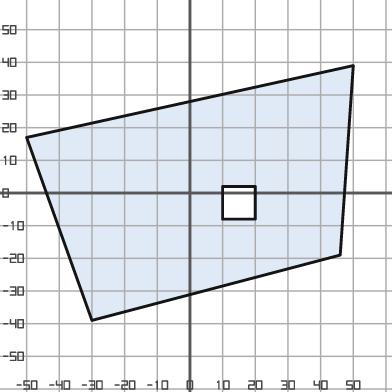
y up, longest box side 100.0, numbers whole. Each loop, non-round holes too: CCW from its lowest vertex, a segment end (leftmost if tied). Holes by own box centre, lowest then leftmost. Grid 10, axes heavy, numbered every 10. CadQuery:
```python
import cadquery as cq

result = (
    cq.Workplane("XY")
    .moveTo(-30.0, -39.0)
    .lineTo(46.0, -19.0)
    .lineTo(50.0, 39.0)
    .lineTo(-50.0, 17.0)
    .close()
    .moveTo(10.0, -8.0)
    .lineTo(20.0, -8.0)
    .lineTo(20.0, 2.0)
    .lineTo(10.0, 2.0)
    .close()
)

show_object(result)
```